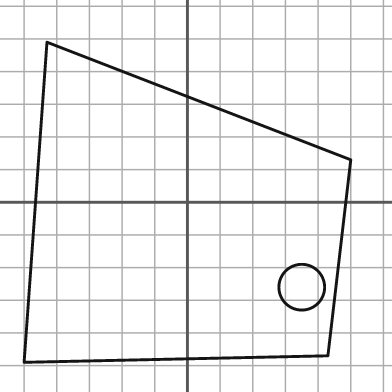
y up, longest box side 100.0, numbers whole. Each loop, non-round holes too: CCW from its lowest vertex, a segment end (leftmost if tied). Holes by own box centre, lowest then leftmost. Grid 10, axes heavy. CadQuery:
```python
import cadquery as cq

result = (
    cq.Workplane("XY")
    .moveTo(-50.0, -49.0)
    .lineTo(43.0, -47.0)
    .lineTo(50.0, 13.0)
    .lineTo(-43.0, 49.0)
    .close()
    .moveTo(35.0, -26.0)
    .circle(7.0)
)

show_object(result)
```